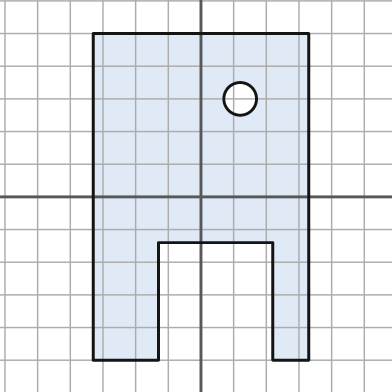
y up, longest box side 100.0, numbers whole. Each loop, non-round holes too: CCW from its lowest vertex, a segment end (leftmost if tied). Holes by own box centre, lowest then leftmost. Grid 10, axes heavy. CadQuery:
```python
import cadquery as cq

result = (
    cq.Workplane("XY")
    .moveTo(-33.0, -50.0)
    .lineTo(-13.0, -50.0)
    .lineTo(-13.0, -14.0)
    .lineTo(22.0, -14.0)
    .lineTo(22.0, -50.0)
    .lineTo(33.0, -50.0)
    .lineTo(33.0, 50.0)
    .lineTo(-33.0, 50.0)
    .close()
    .moveTo(12.0, 30.0)
    .circle(5.0)
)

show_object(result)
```